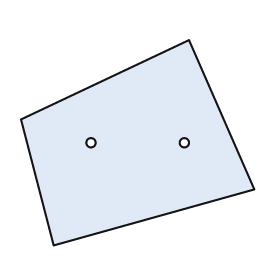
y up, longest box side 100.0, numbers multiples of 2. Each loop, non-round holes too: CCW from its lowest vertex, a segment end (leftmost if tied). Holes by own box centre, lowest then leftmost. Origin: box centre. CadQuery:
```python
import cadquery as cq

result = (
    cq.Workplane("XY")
    .moveTo(-36.0, -44.0)
    .lineTo(50.0, -20.0)
    .lineTo(22.0, 44.0)
    .lineTo(-50.0, 10.0)
    .close()
    .moveTo(-20.0, 0.0)
    .circle(2.0)
    .moveTo(20.0, 0.0)
    .circle(2.0)
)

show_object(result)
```